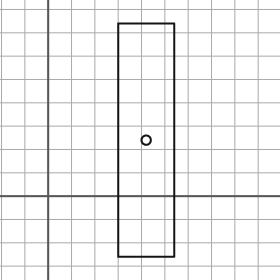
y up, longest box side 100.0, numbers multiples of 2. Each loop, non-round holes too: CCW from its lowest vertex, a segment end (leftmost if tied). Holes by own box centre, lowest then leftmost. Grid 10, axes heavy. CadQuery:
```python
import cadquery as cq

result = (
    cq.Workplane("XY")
    .moveTo(30.0, -26.0)
    .lineTo(54.0, -26.0)
    .lineTo(54.0, 74.0)
    .lineTo(30.0, 74.0)
    .close()
    .moveTo(42.0, 24.0)
    .circle(2.0)
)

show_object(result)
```